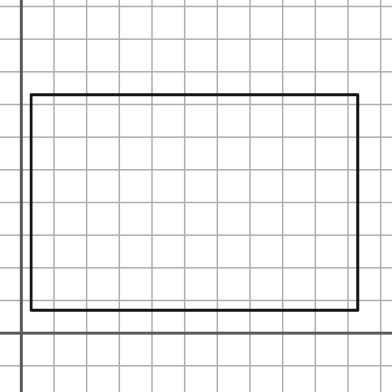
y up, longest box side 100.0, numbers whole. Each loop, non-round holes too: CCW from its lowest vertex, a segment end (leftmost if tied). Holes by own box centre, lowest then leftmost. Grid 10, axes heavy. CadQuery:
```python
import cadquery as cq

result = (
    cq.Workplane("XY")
    .moveTo(3.0, 7.0)
    .lineTo(103.0, 7.0)
    .lineTo(103.0, 73.0)
    .lineTo(3.0, 73.0)
    .close()
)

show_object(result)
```